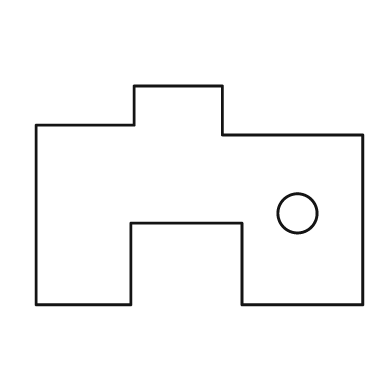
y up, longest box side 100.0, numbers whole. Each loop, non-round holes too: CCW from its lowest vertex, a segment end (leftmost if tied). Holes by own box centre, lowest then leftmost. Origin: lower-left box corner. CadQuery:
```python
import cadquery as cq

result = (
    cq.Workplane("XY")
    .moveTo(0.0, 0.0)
    .lineTo(29.0, 0.0)
    .lineTo(29.0, 25.0)
    .lineTo(63.0, 25.0)
    .lineTo(63.0, 0.0)
    .lineTo(100.0, 0.0)
    .lineTo(100.0, 52.0)
    .lineTo(57.0, 52.0)
    .lineTo(57.0, 67.0)
    .lineTo(30.0, 67.0)
    .lineTo(30.0, 55.0)
    .lineTo(0.0, 55.0)
    .close()
    .moveTo(80.0, 28.0)
    .circle(6.0)
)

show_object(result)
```